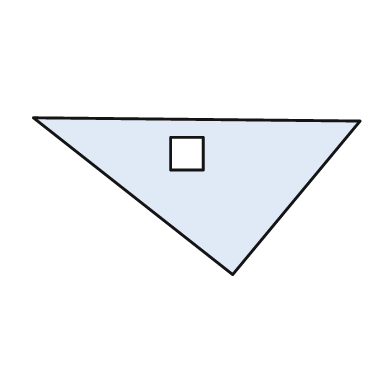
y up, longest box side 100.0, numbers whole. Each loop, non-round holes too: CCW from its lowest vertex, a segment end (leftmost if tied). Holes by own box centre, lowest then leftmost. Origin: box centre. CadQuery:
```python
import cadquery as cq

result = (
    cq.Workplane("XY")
    .moveTo(11.0, -24.0)
    .lineTo(50.0, 23.0)
    .lineTo(-50.0, 24.0)
    .close()
    .moveTo(-8.0, 8.0)
    .lineTo(2.0, 8.0)
    .lineTo(2.0, 18.0)
    .lineTo(-8.0, 18.0)
    .close()
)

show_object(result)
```